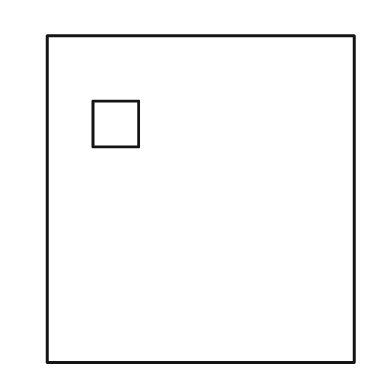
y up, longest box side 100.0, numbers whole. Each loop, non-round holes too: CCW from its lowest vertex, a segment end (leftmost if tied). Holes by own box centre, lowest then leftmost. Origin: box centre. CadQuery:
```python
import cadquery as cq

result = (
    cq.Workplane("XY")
    .moveTo(-47.0, -50.0)
    .lineTo(47.0, -50.0)
    .lineTo(47.0, 50.0)
    .lineTo(-47.0, 50.0)
    .close()
    .moveTo(-33.0, 16.0)
    .lineTo(-19.0, 16.0)
    .lineTo(-19.0, 30.0)
    .lineTo(-33.0, 30.0)
    .close()
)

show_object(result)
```